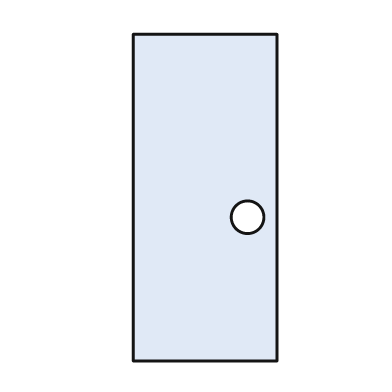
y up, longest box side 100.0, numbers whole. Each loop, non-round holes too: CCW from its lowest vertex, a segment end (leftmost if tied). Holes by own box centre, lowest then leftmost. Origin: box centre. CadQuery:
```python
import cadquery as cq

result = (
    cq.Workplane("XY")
    .moveTo(-22.0, -50.0)
    .lineTo(22.0, -50.0)
    .lineTo(22.0, 50.0)
    .lineTo(-22.0, 50.0)
    .close()
    .moveTo(13.0, -6.0)
    .circle(5.0)
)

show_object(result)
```